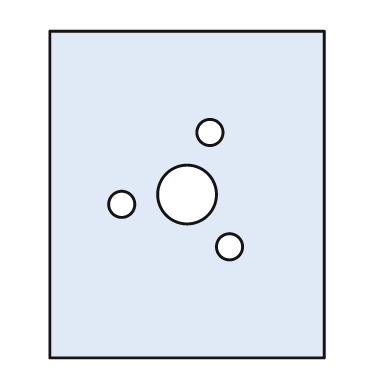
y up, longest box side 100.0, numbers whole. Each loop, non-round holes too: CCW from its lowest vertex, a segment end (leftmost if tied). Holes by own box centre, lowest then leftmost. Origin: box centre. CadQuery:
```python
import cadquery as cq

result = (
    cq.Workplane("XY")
    .moveTo(-42.0, -50.0)
    .lineTo(42.0, -50.0)
    .lineTo(42.0, 50.0)
    .lineTo(-42.0, 50.0)
    .close()
    .moveTo(13.0, -16.0)
    .circle(4.0)
    .moveTo(-20.0, -3.0)
    .circle(4.0)
    .moveTo(0.0, 0.0)
    .circle(9.0)
    .moveTo(7.0, 19.0)
    .circle(4.0)
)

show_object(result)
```